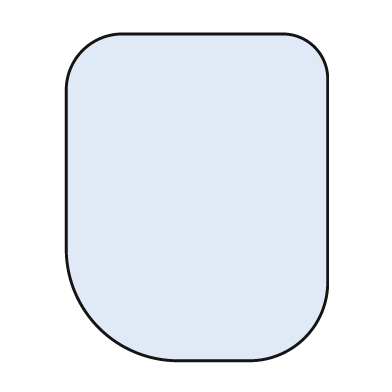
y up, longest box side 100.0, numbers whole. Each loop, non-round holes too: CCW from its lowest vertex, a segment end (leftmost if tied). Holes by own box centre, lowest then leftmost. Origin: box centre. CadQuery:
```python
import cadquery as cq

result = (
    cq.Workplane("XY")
    .moveTo(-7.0, -50.0)
    .lineTo(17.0, -50.0)
    .threePointArc((33.0, -43.0), (40.0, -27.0))
    .lineTo(40.0, 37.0)
    .threePointArc((36.0, 46.0), (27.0, 50.0))
    .lineTo(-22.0, 50.0)
    .threePointArc((-35.0, 45.0), (-40.0, 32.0))
    .lineTo(-40.0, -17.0)
    .threePointArc((-30.0, -40.0), (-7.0, -50.0))
    .close()
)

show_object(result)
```